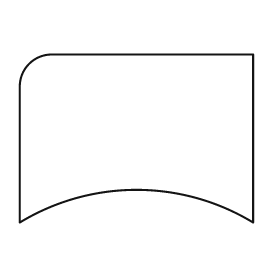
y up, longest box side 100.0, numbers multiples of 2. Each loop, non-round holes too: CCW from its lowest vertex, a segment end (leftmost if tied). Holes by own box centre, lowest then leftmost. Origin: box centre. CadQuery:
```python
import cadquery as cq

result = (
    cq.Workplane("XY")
    .moveTo(-50.0, -36.0)
    .threePointArc((0.0, -22.0), (50.0, -36.0))
    .lineTo(50.0, 36.0)
    .lineTo(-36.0, 36.0)
    .threePointArc((-46.0, 32.0), (-50.0, 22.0))
    .close()
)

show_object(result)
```